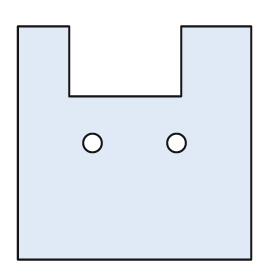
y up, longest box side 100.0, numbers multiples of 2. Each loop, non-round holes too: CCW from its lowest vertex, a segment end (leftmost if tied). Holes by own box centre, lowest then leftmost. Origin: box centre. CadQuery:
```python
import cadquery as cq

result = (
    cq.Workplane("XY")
    .moveTo(-50.0, -50.0)
    .lineTo(50.0, -50.0)
    .lineTo(50.0, 50.0)
    .lineTo(20.0, 50.0)
    .lineTo(20.0, 20.0)
    .lineTo(-28.0, 20.0)
    .lineTo(-28.0, 50.0)
    .lineTo(-50.0, 50.0)
    .close()
    .moveTo(-18.0, 0.0)
    .circle(4.0)
    .moveTo(18.0, 0.0)
    .circle(4.0)
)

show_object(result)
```